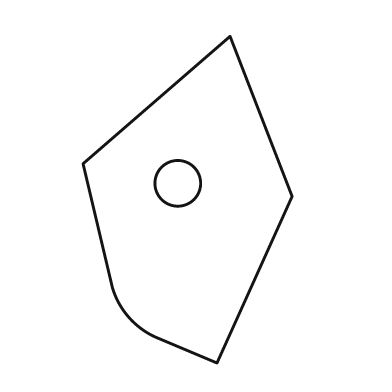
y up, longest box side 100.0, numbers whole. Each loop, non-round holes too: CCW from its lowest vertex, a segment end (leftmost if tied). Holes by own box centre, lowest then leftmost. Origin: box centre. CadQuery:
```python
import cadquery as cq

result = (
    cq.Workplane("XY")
    .moveTo(9.0, -50.0)
    .lineTo(32.0, 1.0)
    .lineTo(13.0, 50.0)
    .lineTo(-32.0, 11.0)
    .lineTo(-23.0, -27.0)
    .threePointArc((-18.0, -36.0), (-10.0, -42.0))
    .close()
    .moveTo(-3.0, 5.0)
    .circle(7.0)
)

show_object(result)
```